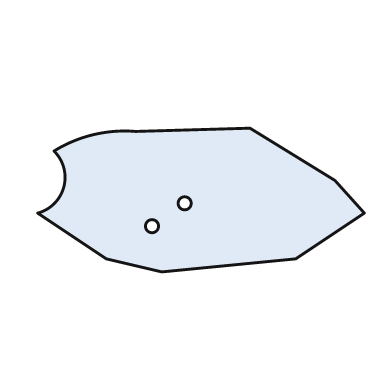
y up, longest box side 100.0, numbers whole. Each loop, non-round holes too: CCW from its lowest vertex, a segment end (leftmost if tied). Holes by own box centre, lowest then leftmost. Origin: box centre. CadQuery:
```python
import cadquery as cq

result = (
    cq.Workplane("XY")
    .moveTo(-12.0, -22.0)
    .lineTo(29.0, -18.0)
    .lineTo(50.0, -4.0)
    .lineTo(41.0, 6.0)
    .lineTo(15.0, 22.0)
    .lineTo(-20.0, 21.0)
    .threePointArc((-33.0, 20.0), (-45.0, 15.0))
    .threePointArc((-42.0, 4.0), (-50.0, -4.0))
    .lineTo(-29.0, -18.0)
    .close()
    .moveTo(-15.0, -8.0)
    .circle(2.0)
    .moveTo(-5.0, -1.0)
    .circle(2.0)
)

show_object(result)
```